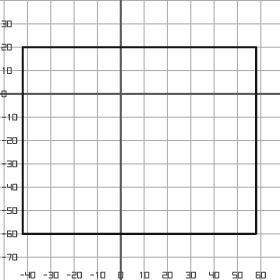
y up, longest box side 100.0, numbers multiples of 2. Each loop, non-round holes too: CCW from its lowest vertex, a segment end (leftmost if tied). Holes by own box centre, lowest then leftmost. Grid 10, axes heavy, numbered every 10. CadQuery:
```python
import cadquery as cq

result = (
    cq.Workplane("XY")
    .moveTo(-42.0, -60.0)
    .lineTo(58.0, -60.0)
    .lineTo(58.0, 20.0)
    .lineTo(-42.0, 20.0)
    .close()
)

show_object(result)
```